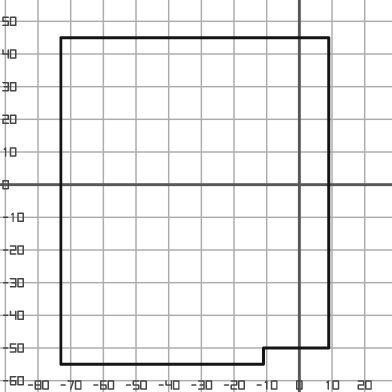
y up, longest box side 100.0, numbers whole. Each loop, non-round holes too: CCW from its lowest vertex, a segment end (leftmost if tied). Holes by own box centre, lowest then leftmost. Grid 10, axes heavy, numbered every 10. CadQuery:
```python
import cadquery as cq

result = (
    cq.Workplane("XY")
    .moveTo(-73.0, -55.0)
    .lineTo(-11.0, -55.0)
    .lineTo(-11.0, -50.0)
    .lineTo(9.0, -50.0)
    .lineTo(9.0, 45.0)
    .lineTo(-73.0, 45.0)
    .close()
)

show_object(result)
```